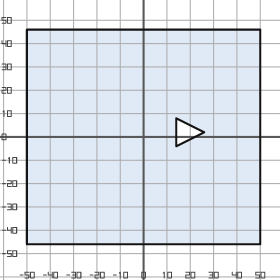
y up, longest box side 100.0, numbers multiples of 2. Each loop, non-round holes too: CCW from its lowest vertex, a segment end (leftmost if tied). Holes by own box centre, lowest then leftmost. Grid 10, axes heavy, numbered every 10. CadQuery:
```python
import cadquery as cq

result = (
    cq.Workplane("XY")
    .moveTo(-50.0, -46.0)
    .lineTo(50.0, -46.0)
    .lineTo(50.0, 46.0)
    .lineTo(-50.0, 46.0)
    .close()
    .moveTo(14.0, -4.0)
    .lineTo(26.0, 2.0)
    .lineTo(14.0, 8.0)
    .close()
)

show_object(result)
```